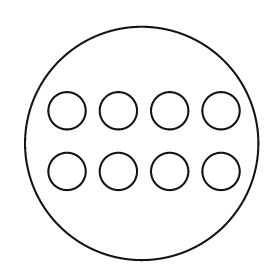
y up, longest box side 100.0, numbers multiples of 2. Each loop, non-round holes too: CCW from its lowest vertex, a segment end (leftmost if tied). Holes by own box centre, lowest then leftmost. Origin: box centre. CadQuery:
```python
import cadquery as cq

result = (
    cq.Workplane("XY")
    .moveTo(0.0, 0.0)
    .circle(50.0)
    .moveTo(-32.0, -12.0)
    .circle(8.0)
    .moveTo(-10.0, -12.0)
    .circle(8.0)
    .moveTo(12.0, -12.0)
    .circle(8.0)
    .moveTo(34.0, -12.0)
    .circle(8.0)
    .moveTo(-32.0, 14.0)
    .circle(8.0)
    .moveTo(-10.0, 14.0)
    .circle(8.0)
    .moveTo(12.0, 14.0)
    .circle(8.0)
    .moveTo(34.0, 14.0)
    .circle(8.0)
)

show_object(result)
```